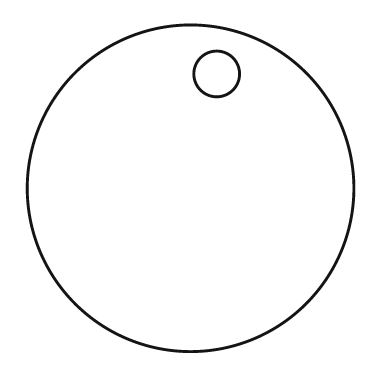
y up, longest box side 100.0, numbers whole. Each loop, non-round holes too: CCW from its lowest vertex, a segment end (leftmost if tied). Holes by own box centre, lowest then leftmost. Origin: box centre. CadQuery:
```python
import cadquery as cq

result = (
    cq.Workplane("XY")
    .moveTo(0.0, 0.0)
    .circle(50.0)
    .moveTo(8.0, 35.0)
    .circle(7.0)
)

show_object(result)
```